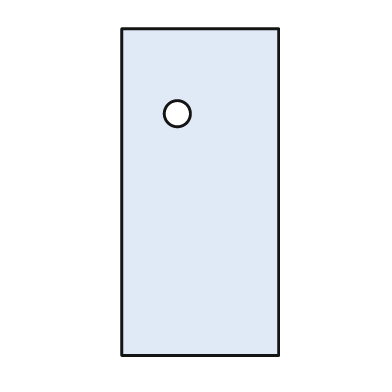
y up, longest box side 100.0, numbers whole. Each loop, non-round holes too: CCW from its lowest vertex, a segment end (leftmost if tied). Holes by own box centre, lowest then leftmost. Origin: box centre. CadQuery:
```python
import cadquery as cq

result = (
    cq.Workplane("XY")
    .moveTo(-24.0, -50.0)
    .lineTo(24.0, -50.0)
    .lineTo(24.0, 50.0)
    .lineTo(-24.0, 50.0)
    .close()
    .moveTo(-7.0, 24.0)
    .circle(4.0)
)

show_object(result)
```